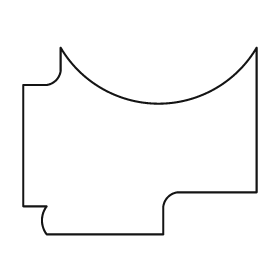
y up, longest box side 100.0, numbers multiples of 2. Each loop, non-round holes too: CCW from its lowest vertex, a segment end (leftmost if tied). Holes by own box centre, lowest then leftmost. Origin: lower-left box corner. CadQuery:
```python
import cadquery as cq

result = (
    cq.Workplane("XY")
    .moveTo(10.0, 0.0)
    .lineTo(60.0, 0.0)
    .lineTo(60.0, 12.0)
    .threePointArc((62.0, 16.0), (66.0, 18.0))
    .lineTo(100.0, 18.0)
    .lineTo(100.0, 80.0)
    .threePointArc((58.0, 56.0), (16.0, 80.0))
    .lineTo(16.0, 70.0)
    .threePointArc((14.0, 66.0), (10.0, 64.0))
    .lineTo(0.0, 64.0)
    .lineTo(0.0, 12.0)
    .lineTo(10.0, 12.0)
    .threePointArc((8.0, 6.0), (10.0, 0.0))
    .close()
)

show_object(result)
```